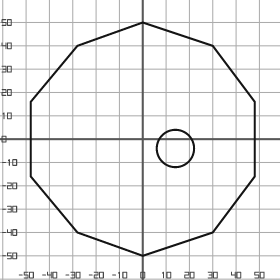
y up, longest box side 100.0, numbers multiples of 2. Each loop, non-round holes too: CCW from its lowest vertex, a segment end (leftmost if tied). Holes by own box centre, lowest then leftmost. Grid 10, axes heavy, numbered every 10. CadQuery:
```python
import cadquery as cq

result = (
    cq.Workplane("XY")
    .moveTo(0.0, -50.0)
    .lineTo(30.0, -40.0)
    .lineTo(48.0, -16.0)
    .lineTo(48.0, 16.0)
    .lineTo(30.0, 40.0)
    .lineTo(0.0, 50.0)
    .lineTo(-28.0, 40.0)
    .lineTo(-48.0, 16.0)
    .lineTo(-48.0, -16.0)
    .lineTo(-28.0, -40.0)
    .close()
    .moveTo(14.0, -4.0)
    .circle(8.0)
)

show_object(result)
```